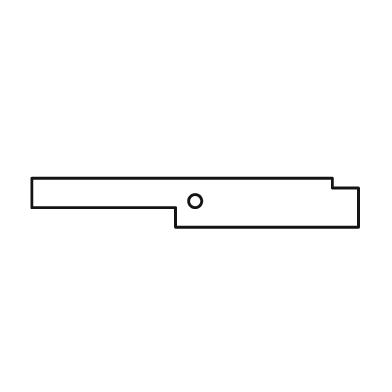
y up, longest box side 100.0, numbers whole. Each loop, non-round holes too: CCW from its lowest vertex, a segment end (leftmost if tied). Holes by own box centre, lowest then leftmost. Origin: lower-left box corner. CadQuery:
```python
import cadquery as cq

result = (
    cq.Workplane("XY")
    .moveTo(44.0, 0.0)
    .lineTo(100.0, 0.0)
    .lineTo(100.0, 12.0)
    .lineTo(92.0, 12.0)
    .lineTo(92.0, 15.0)
    .lineTo(0.0, 15.0)
    .lineTo(0.0, 6.0)
    .lineTo(44.0, 6.0)
    .close()
    .moveTo(50.0, 8.0)
    .circle(2.0)
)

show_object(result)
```